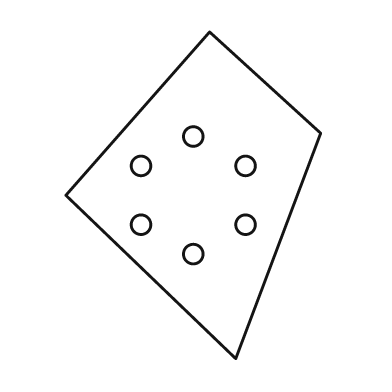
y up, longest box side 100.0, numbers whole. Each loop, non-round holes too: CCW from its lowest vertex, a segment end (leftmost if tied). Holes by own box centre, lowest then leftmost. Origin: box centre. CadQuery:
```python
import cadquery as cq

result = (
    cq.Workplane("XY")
    .moveTo(13.0, -50.0)
    .lineTo(39.0, 19.0)
    .lineTo(5.0, 50.0)
    .lineTo(-39.0, 0.0)
    .close()
    .moveTo(0.0, -18.0)
    .circle(3.0)
    .moveTo(-16.0, -9.0)
    .circle(3.0)
    .moveTo(16.0, -9.0)
    .circle(3.0)
    .moveTo(-16.0, 9.0)
    .circle(3.0)
    .moveTo(16.0, 9.0)
    .circle(3.0)
    .moveTo(0.0, 18.0)
    .circle(3.0)
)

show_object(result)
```